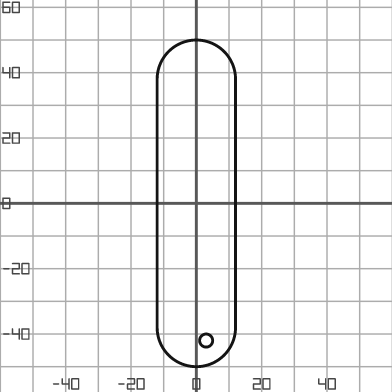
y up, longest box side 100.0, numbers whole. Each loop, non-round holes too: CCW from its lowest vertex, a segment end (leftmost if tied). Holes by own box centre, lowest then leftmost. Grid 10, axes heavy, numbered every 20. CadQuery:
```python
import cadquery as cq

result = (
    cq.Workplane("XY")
    .moveTo(-12.0, -38.0)
    .threePointArc((0.0, -50.0), (12.0, -38.0))
    .lineTo(12.0, 38.0)
    .threePointArc((0.0, 50.0), (-12.0, 38.0))
    .close()
    .moveTo(3.0, -42.0)
    .circle(2.0)
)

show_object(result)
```